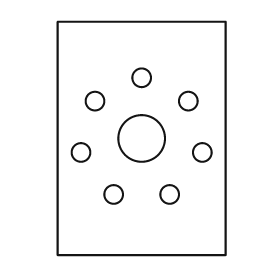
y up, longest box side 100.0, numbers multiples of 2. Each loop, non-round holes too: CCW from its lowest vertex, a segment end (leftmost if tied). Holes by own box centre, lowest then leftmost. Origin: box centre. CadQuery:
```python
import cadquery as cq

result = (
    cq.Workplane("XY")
    .moveTo(-36.0, -50.0)
    .lineTo(36.0, -50.0)
    .lineTo(36.0, 50.0)
    .lineTo(-36.0, 50.0)
    .close()
    .moveTo(-12.0, -24.0)
    .circle(4.0)
    .moveTo(12.0, -24.0)
    .circle(4.0)
    .moveTo(-26.0, -6.0)
    .circle(4.0)
    .moveTo(26.0, -6.0)
    .circle(4.0)
    .moveTo(0.0, 0.0)
    .circle(10.0)
    .moveTo(-20.0, 16.0)
    .circle(4.0)
    .moveTo(20.0, 16.0)
    .circle(4.0)
    .moveTo(0.0, 26.0)
    .circle(4.0)
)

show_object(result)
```